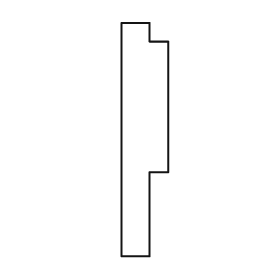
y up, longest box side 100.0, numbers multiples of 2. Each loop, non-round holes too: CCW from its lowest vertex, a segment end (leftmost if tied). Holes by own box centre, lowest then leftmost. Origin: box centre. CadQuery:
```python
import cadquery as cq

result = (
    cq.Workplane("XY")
    .moveTo(-10.0, -50.0)
    .lineTo(2.0, -50.0)
    .lineTo(2.0, -14.0)
    .lineTo(10.0, -14.0)
    .lineTo(10.0, 42.0)
    .lineTo(2.0, 42.0)
    .lineTo(2.0, 50.0)
    .lineTo(-10.0, 50.0)
    .close()
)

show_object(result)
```